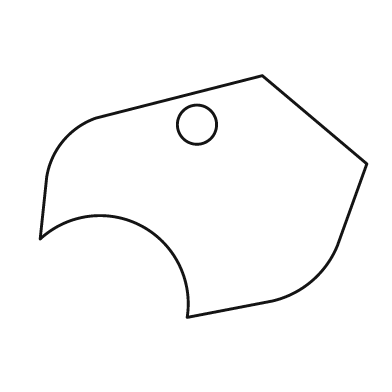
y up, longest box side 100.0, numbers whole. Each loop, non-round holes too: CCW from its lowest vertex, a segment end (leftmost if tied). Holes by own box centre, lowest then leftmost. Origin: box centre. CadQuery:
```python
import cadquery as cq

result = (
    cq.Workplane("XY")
    .moveTo(-5.0, -37.0)
    .lineTo(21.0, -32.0)
    .threePointArc((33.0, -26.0), (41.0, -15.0))
    .lineTo(50.0, 10.0)
    .lineTo(18.0, 37.0)
    .lineTo(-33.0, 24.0)
    .threePointArc((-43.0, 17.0), (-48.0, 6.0))
    .lineTo(-50.0, -13.0)
    .threePointArc((-19.0, -9.0), (-5.0, -37.0))
    .close()
    .moveTo(-2.0, 22.0)
    .circle(6.0)
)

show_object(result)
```